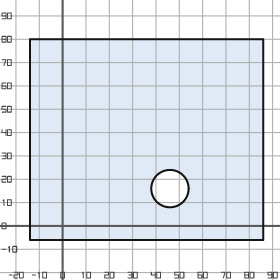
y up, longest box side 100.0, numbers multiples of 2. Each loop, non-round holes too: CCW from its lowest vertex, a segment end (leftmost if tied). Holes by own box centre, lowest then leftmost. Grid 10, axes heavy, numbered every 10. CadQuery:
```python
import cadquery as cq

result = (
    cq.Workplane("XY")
    .moveTo(-14.0, -6.0)
    .lineTo(86.0, -6.0)
    .lineTo(86.0, 80.0)
    .lineTo(-14.0, 80.0)
    .close()
    .moveTo(46.0, 16.0)
    .circle(8.0)
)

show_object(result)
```